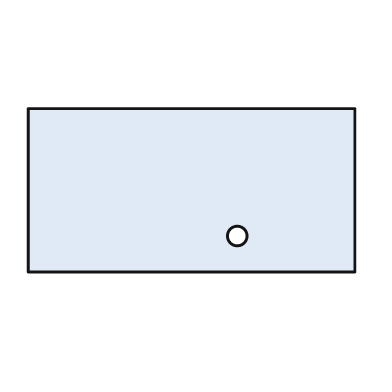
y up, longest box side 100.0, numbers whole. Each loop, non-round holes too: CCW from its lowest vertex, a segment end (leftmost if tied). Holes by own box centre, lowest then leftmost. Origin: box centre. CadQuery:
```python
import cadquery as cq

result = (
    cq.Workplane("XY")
    .moveTo(-50.0, -25.0)
    .lineTo(50.0, -25.0)
    .lineTo(50.0, 25.0)
    .lineTo(-50.0, 25.0)
    .close()
    .moveTo(14.0, -14.0)
    .circle(3.0)
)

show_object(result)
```